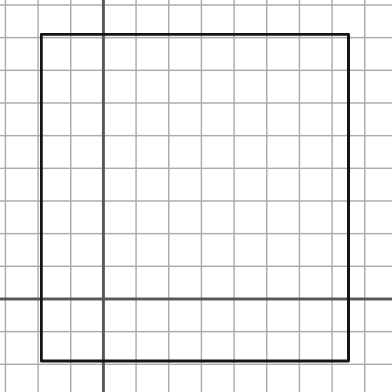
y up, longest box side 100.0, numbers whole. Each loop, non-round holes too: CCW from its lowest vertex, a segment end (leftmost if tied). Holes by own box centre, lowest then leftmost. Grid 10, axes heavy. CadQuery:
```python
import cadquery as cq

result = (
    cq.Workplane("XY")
    .moveTo(-19.0, -19.0)
    .lineTo(75.0, -19.0)
    .lineTo(75.0, 81.0)
    .lineTo(-19.0, 81.0)
    .close()
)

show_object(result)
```